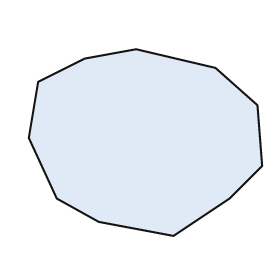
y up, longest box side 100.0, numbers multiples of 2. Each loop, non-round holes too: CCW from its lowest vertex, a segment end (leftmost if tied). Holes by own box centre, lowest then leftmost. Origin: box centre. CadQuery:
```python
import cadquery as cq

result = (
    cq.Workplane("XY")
    .moveTo(12.0, -40.0)
    .lineTo(36.0, -24.0)
    .lineTo(50.0, -10.0)
    .lineTo(48.0, 16.0)
    .lineTo(30.0, 32.0)
    .lineTo(-4.0, 40.0)
    .lineTo(-26.0, 36.0)
    .lineTo(-46.0, 26.0)
    .lineTo(-50.0, 2.0)
    .lineTo(-38.0, -24.0)
    .lineTo(-20.0, -34.0)
    .close()
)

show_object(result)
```